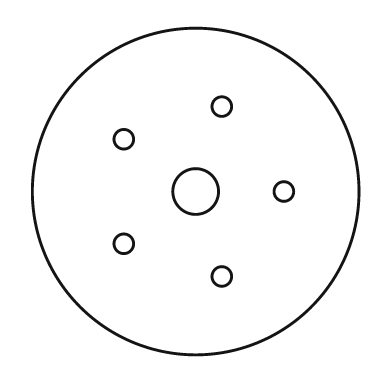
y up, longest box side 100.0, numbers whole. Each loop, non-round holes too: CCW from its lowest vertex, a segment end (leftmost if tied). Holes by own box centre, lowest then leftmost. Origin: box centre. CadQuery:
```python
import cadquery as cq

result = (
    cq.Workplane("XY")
    .moveTo(0.0, 0.0)
    .circle(50.0)
    .moveTo(8.0, -26.0)
    .circle(3.0)
    .moveTo(-22.0, -16.0)
    .circle(3.0)
    .moveTo(0.0, 0.0)
    .circle(7.0)
    .moveTo(27.0, 0.0)
    .circle(3.0)
    .moveTo(-22.0, 16.0)
    .circle(3.0)
    .moveTo(8.0, 26.0)
    .circle(3.0)
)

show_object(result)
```